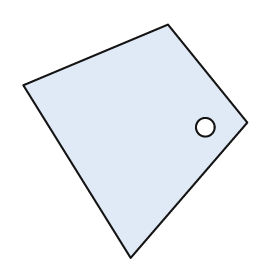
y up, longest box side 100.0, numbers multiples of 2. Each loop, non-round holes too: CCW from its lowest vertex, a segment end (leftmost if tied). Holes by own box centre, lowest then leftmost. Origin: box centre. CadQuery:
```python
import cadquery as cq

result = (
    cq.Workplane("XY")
    .moveTo(-2.0, -50.0)
    .lineTo(48.0, 8.0)
    .lineTo(14.0, 50.0)
    .lineTo(-48.0, 24.0)
    .close()
    .moveTo(30.0, 6.0)
    .circle(4.0)
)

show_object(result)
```